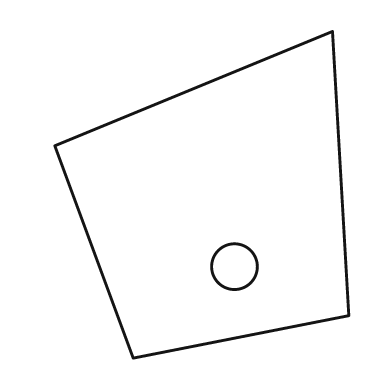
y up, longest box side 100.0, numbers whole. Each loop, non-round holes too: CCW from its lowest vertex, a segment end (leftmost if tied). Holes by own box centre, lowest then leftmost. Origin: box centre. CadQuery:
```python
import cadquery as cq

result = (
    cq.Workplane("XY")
    .moveTo(-21.0, -50.0)
    .lineTo(45.0, -37.0)
    .lineTo(40.0, 50.0)
    .lineTo(-45.0, 15.0)
    .close()
    .moveTo(10.0, -22.0)
    .circle(7.0)
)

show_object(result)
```